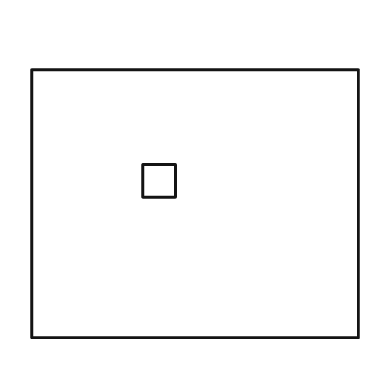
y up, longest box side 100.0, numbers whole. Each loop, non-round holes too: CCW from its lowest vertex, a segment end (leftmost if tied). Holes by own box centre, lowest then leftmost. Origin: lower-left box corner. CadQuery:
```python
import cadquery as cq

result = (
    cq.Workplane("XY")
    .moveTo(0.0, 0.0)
    .lineTo(100.0, 0.0)
    .lineTo(100.0, 82.0)
    .lineTo(0.0, 82.0)
    .close()
    .moveTo(34.0, 43.0)
    .lineTo(44.0, 43.0)
    .lineTo(44.0, 53.0)
    .lineTo(34.0, 53.0)
    .close()
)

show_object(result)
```